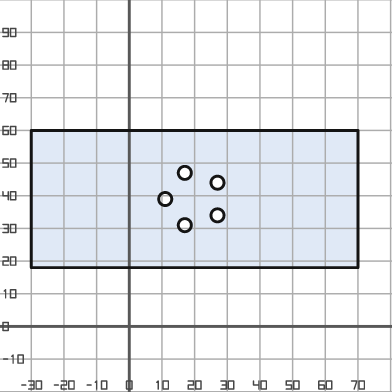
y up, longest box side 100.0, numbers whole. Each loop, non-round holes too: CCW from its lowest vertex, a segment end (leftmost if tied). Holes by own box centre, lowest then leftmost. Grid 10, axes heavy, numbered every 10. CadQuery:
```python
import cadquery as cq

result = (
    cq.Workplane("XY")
    .moveTo(-30.0, 18.0)
    .lineTo(70.0, 18.0)
    .lineTo(70.0, 60.0)
    .lineTo(-30.0, 60.0)
    .close()
    .moveTo(17.0, 31.0)
    .circle(2.0)
    .moveTo(27.0, 34.0)
    .circle(2.0)
    .moveTo(11.0, 39.0)
    .circle(2.0)
    .moveTo(27.0, 44.0)
    .circle(2.0)
    .moveTo(17.0, 47.0)
    .circle(2.0)
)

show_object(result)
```